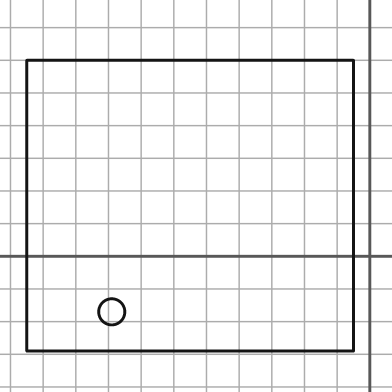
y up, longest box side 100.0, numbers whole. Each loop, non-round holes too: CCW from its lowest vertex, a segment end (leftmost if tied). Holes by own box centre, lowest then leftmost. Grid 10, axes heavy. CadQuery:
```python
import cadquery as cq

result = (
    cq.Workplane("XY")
    .moveTo(-105.0, -29.0)
    .lineTo(-5.0, -29.0)
    .lineTo(-5.0, 60.0)
    .lineTo(-105.0, 60.0)
    .close()
    .moveTo(-79.0, -17.0)
    .circle(4.0)
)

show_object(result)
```